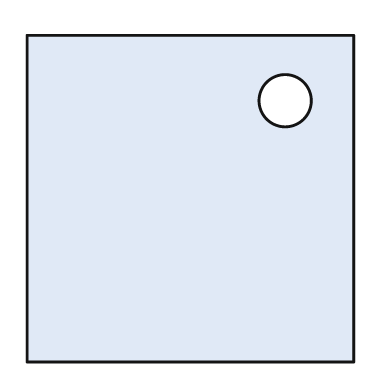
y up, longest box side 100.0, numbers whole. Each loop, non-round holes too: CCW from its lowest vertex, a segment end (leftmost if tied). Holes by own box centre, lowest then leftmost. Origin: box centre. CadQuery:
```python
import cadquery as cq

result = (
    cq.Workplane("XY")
    .moveTo(-50.0, -50.0)
    .lineTo(50.0, -50.0)
    .lineTo(50.0, 50.0)
    .lineTo(-50.0, 50.0)
    .close()
    .moveTo(29.0, 30.0)
    .circle(8.0)
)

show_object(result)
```